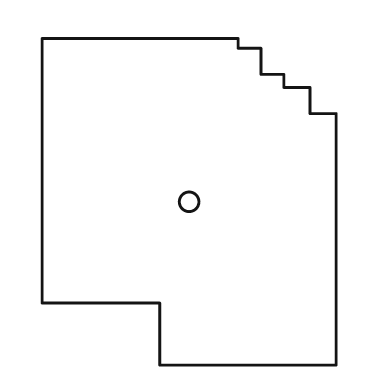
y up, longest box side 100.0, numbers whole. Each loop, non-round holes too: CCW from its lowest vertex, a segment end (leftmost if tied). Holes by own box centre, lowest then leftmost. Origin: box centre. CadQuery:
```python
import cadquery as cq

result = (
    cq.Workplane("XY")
    .moveTo(-9.0, -50.0)
    .lineTo(45.0, -50.0)
    .lineTo(45.0, 27.0)
    .lineTo(37.0, 27.0)
    .lineTo(37.0, 35.0)
    .lineTo(29.0, 35.0)
    .lineTo(29.0, 39.0)
    .lineTo(22.0, 39.0)
    .lineTo(22.0, 47.0)
    .lineTo(15.0, 47.0)
    .lineTo(15.0, 50.0)
    .lineTo(-45.0, 50.0)
    .lineTo(-45.0, -31.0)
    .lineTo(-9.0, -31.0)
    .close()
    .moveTo(0.0, 0.0)
    .circle(3.0)
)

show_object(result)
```